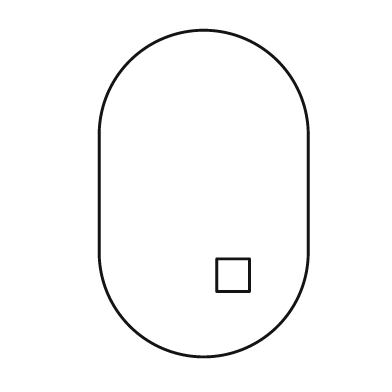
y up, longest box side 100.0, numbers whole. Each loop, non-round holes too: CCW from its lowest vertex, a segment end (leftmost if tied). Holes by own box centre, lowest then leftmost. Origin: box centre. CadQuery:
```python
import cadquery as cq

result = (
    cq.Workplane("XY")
    .moveTo(-32.0, -18.0)
    .threePointArc((0.0, -50.0), (32.0, -18.0))
    .lineTo(32.0, 18.0)
    .threePointArc((0.0, 50.0), (-32.0, 18.0))
    .close()
    .moveTo(4.0, -30.0)
    .lineTo(14.0, -30.0)
    .lineTo(14.0, -20.0)
    .lineTo(4.0, -20.0)
    .close()
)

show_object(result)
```